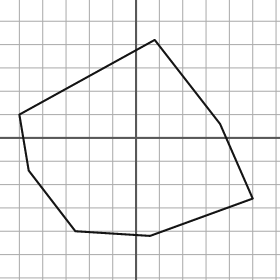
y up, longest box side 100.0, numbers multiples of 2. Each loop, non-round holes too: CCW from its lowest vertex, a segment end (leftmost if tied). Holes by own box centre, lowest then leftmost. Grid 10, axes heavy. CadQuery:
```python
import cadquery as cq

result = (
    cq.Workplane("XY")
    .moveTo(6.0, -42.0)
    .lineTo(50.0, -26.0)
    .lineTo(36.0, 6.0)
    .lineTo(8.0, 42.0)
    .lineTo(-50.0, 10.0)
    .lineTo(-46.0, -14.0)
    .lineTo(-26.0, -40.0)
    .close()
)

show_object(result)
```